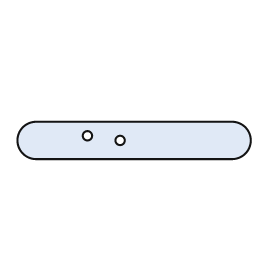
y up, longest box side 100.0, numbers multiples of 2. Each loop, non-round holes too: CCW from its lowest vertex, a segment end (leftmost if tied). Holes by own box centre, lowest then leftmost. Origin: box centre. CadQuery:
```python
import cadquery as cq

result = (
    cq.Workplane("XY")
    .moveTo(-42.0, -8.0)
    .lineTo(42.0, -8.0)
    .threePointArc((50.0, 0.0), (42.0, 8.0))
    .lineTo(-42.0, 8.0)
    .threePointArc((-50.0, 0.0), (-42.0, -8.0))
    .close()
    .moveTo(-6.0, 0.0)
    .circle(2.0)
    .moveTo(-20.0, 2.0)
    .circle(2.0)
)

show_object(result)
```